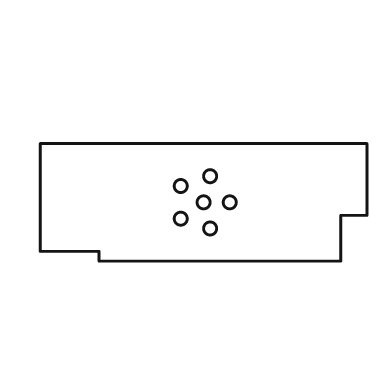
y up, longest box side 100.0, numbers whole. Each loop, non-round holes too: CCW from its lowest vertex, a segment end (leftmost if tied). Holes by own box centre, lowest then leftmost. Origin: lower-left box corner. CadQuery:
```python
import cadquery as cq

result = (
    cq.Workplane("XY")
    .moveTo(18.0, 0.0)
    .lineTo(92.0, 0.0)
    .lineTo(92.0, 14.0)
    .lineTo(100.0, 14.0)
    .lineTo(100.0, 36.0)
    .lineTo(0.0, 36.0)
    .lineTo(0.0, 3.0)
    .lineTo(18.0, 3.0)
    .close()
    .moveTo(52.0, 10.0)
    .circle(2.0)
    .moveTo(43.0, 13.0)
    .circle(2.0)
    .moveTo(50.0, 18.0)
    .circle(2.0)
    .moveTo(58.0, 18.0)
    .circle(2.0)
    .moveTo(43.0, 23.0)
    .circle(2.0)
    .moveTo(52.0, 26.0)
    .circle(2.0)
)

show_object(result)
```